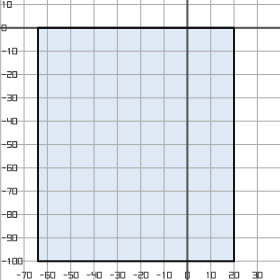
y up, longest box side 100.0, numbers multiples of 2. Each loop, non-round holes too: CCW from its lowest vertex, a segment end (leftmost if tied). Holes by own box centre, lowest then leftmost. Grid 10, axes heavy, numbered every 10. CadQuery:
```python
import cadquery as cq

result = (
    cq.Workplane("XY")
    .moveTo(-64.0, -100.0)
    .lineTo(20.0, -100.0)
    .lineTo(20.0, 0.0)
    .lineTo(-64.0, 0.0)
    .close()
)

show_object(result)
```